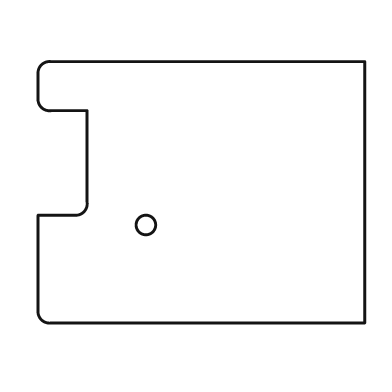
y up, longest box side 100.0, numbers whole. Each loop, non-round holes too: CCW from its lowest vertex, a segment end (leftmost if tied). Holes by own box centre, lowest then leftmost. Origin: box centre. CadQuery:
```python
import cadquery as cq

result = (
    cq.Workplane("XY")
    .moveTo(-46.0, -40.0)
    .lineTo(50.0, -40.0)
    .lineTo(50.0, 40.0)
    .lineTo(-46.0, 40.0)
    .threePointArc((-49.0, 39.0), (-50.0, 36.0))
    .lineTo(-50.0, 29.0)
    .threePointArc((-49.0, 26.0), (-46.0, 25.0))
    .lineTo(-35.0, 25.0)
    .lineTo(-35.0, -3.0)
    .threePointArc((-36.0, -6.0), (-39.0, -7.0))
    .lineTo(-50.0, -7.0)
    .lineTo(-50.0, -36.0)
    .threePointArc((-49.0, -39.0), (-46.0, -40.0))
    .close()
    .moveTo(-17.0, -10.0)
    .circle(3.0)
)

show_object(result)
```